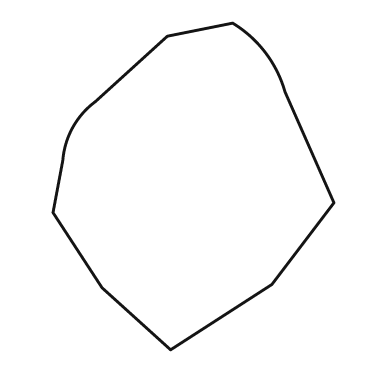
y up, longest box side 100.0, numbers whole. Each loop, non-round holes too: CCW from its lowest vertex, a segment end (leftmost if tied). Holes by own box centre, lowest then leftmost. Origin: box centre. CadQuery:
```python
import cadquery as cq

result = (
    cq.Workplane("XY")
    .moveTo(-7.0, -50.0)
    .lineTo(24.0, -30.0)
    .lineTo(43.0, -5.0)
    .lineTo(28.0, 29.0)
    .threePointArc((22.0, 41.0), (12.0, 50.0))
    .lineTo(-8.0, 46.0)
    .lineTo(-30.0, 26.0)
    .threePointArc((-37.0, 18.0), (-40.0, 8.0))
    .lineTo(-43.0, -8.0)
    .lineTo(-28.0, -31.0)
    .close()
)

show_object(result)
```